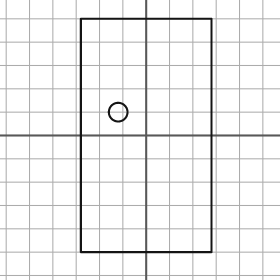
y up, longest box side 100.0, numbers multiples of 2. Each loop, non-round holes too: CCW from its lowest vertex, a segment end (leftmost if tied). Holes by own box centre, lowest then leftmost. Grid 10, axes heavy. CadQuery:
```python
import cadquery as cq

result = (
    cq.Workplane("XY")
    .moveTo(-28.0, -50.0)
    .lineTo(28.0, -50.0)
    .lineTo(28.0, 50.0)
    .lineTo(-28.0, 50.0)
    .close()
    .moveTo(-12.0, 10.0)
    .circle(4.0)
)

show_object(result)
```